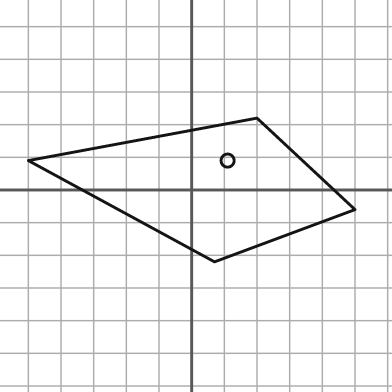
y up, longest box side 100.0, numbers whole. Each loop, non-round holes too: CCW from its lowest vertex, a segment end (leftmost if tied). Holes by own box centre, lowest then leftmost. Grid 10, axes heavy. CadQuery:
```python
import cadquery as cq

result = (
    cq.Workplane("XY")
    .moveTo(7.0, -22.0)
    .lineTo(50.0, -6.0)
    .lineTo(20.0, 22.0)
    .lineTo(-50.0, 9.0)
    .close()
    .moveTo(11.0, 9.0)
    .circle(2.0)
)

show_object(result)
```